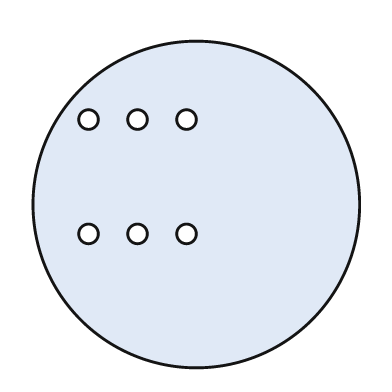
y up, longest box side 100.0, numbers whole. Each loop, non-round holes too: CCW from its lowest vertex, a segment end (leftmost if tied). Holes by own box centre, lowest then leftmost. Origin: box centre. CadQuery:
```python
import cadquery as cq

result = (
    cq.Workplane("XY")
    .moveTo(0.0, 0.0)
    .circle(50.0)
    .moveTo(-33.0, -9.0)
    .circle(3.0)
    .moveTo(-18.0, -9.0)
    .circle(3.0)
    .moveTo(-3.0, -9.0)
    .circle(3.0)
    .moveTo(-33.0, 26.0)
    .circle(3.0)
    .moveTo(-18.0, 26.0)
    .circle(3.0)
    .moveTo(-3.0, 26.0)
    .circle(3.0)
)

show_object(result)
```